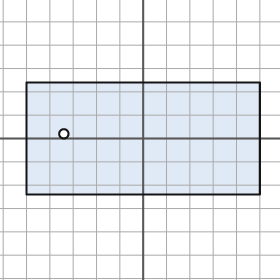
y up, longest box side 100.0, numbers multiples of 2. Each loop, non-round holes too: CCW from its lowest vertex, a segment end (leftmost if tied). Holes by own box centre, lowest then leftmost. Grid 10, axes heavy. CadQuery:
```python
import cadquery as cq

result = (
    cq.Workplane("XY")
    .moveTo(-50.0, -24.0)
    .lineTo(50.0, -24.0)
    .lineTo(50.0, 24.0)
    .lineTo(-50.0, 24.0)
    .close()
    .moveTo(-34.0, 2.0)
    .circle(2.0)
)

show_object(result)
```